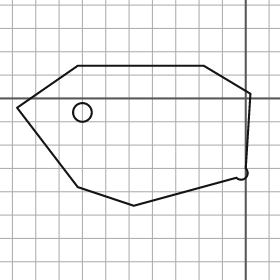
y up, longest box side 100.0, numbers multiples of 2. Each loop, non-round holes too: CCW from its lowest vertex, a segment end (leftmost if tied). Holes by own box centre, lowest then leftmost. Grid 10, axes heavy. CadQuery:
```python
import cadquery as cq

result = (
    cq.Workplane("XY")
    .moveTo(-48.0, -46.0)
    .lineTo(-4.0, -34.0)
    .threePointArc((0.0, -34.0), (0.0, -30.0))
    .lineTo(2.0, 2.0)
    .lineTo(-18.0, 14.0)
    .lineTo(-72.0, 14.0)
    .lineTo(-98.0, -4.0)
    .lineTo(-72.0, -38.0)
    .close()
    .moveTo(-70.0, -6.0)
    .circle(4.0)
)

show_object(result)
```